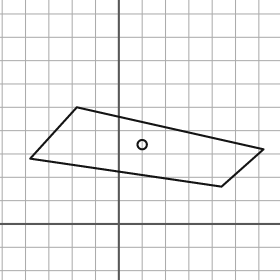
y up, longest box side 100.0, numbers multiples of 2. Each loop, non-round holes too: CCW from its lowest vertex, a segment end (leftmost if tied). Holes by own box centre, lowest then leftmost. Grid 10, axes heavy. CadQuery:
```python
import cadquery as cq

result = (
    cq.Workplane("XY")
    .moveTo(44.0, 16.0)
    .lineTo(62.0, 32.0)
    .lineTo(-18.0, 50.0)
    .lineTo(-38.0, 28.0)
    .close()
    .moveTo(10.0, 34.0)
    .circle(2.0)
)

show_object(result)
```